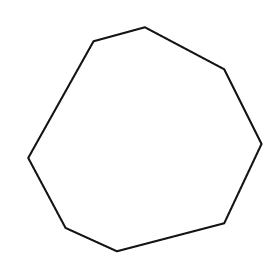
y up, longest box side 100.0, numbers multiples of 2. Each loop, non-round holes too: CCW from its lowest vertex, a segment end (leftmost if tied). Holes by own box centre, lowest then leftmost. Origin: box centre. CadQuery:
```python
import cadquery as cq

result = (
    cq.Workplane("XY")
    .moveTo(-12.0, -48.0)
    .lineTo(34.0, -36.0)
    .lineTo(50.0, -2.0)
    .lineTo(34.0, 30.0)
    .lineTo(0.0, 48.0)
    .lineTo(-22.0, 42.0)
    .lineTo(-50.0, -8.0)
    .lineTo(-34.0, -38.0)
    .close()
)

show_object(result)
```